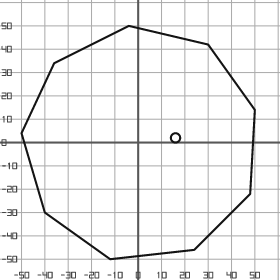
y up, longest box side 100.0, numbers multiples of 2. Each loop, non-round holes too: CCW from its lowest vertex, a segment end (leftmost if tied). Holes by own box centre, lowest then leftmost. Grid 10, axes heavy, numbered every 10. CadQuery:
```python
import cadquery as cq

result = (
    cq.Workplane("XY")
    .moveTo(-12.0, -50.0)
    .lineTo(24.0, -46.0)
    .lineTo(48.0, -22.0)
    .lineTo(50.0, 14.0)
    .lineTo(30.0, 42.0)
    .lineTo(-4.0, 50.0)
    .lineTo(-36.0, 34.0)
    .lineTo(-50.0, 4.0)
    .lineTo(-40.0, -30.0)
    .close()
    .moveTo(16.0, 2.0)
    .circle(2.0)
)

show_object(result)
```